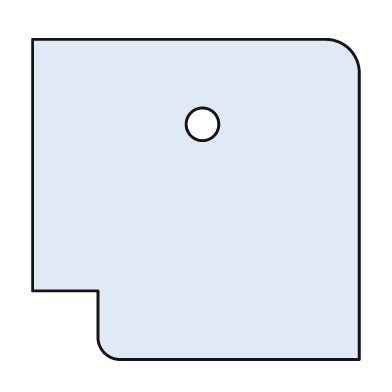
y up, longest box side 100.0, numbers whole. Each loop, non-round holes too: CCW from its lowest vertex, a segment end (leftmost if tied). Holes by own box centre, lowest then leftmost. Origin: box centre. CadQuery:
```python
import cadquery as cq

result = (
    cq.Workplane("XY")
    .moveTo(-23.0, -49.0)
    .lineTo(50.0, -49.0)
    .lineTo(50.0, 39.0)
    .threePointArc((47.0, 46.0), (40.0, 49.0))
    .lineTo(-50.0, 49.0)
    .lineTo(-50.0, -28.0)
    .lineTo(-30.0, -28.0)
    .lineTo(-30.0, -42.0)
    .threePointArc((-28.0, -47.0), (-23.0, -49.0))
    .close()
    .moveTo(2.0, 23.0)
    .circle(5.0)
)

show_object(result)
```